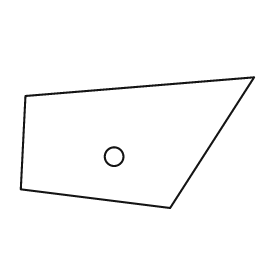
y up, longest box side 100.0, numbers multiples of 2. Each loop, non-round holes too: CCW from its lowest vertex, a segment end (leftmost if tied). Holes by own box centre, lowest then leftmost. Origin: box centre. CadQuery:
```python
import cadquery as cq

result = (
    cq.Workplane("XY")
    .moveTo(14.0, -28.0)
    .lineTo(50.0, 28.0)
    .lineTo(-48.0, 20.0)
    .lineTo(-50.0, -20.0)
    .close()
    .moveTo(-10.0, -6.0)
    .circle(4.0)
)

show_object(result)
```